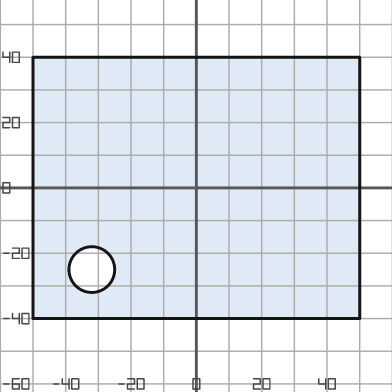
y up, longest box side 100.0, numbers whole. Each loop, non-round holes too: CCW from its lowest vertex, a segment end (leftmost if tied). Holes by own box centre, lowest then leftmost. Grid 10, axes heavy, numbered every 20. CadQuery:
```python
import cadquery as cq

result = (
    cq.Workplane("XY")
    .moveTo(-50.0, -40.0)
    .lineTo(50.0, -40.0)
    .lineTo(50.0, 40.0)
    .lineTo(-50.0, 40.0)
    .close()
    .moveTo(-32.0, -25.0)
    .circle(7.0)
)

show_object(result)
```